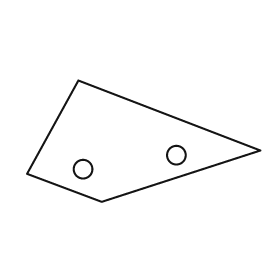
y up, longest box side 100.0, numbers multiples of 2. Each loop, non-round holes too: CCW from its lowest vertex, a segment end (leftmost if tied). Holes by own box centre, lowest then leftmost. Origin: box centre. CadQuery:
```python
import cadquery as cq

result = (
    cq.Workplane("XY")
    .moveTo(-18.0, -26.0)
    .lineTo(50.0, -4.0)
    .lineTo(-28.0, 26.0)
    .lineTo(-50.0, -14.0)
    .close()
    .moveTo(-26.0, -12.0)
    .circle(4.0)
    .moveTo(14.0, -6.0)
    .circle(4.0)
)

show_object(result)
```